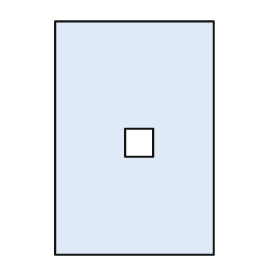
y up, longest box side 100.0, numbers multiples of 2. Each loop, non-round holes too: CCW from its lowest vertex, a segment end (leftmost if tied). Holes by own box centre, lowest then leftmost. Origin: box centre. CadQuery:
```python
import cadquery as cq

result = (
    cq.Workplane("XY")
    .moveTo(-34.0, -50.0)
    .lineTo(34.0, -50.0)
    .lineTo(34.0, 50.0)
    .lineTo(-34.0, 50.0)
    .close()
    .moveTo(-4.0, -8.0)
    .lineTo(8.0, -8.0)
    .lineTo(8.0, 4.0)
    .lineTo(-4.0, 4.0)
    .close()
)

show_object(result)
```